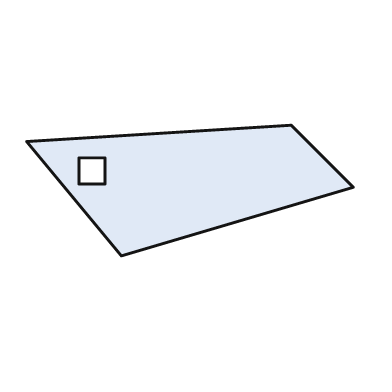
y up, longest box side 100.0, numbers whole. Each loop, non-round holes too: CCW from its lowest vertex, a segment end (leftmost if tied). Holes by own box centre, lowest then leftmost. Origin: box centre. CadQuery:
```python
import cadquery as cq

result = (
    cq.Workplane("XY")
    .moveTo(-21.0, -20.0)
    .lineTo(50.0, 1.0)
    .lineTo(31.0, 20.0)
    .lineTo(-50.0, 15.0)
    .close()
    .moveTo(-34.0, 2.0)
    .lineTo(-26.0, 2.0)
    .lineTo(-26.0, 10.0)
    .lineTo(-34.0, 10.0)
    .close()
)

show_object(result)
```